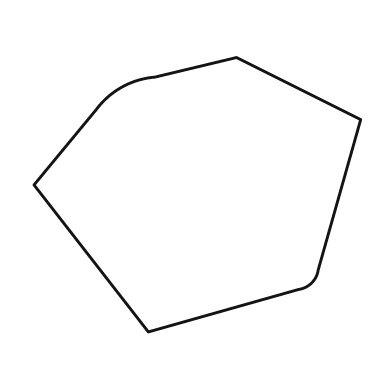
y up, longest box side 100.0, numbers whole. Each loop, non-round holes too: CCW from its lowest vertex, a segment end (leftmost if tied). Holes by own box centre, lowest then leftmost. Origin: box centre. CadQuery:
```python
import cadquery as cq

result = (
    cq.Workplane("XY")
    .moveTo(-15.0, -42.0)
    .lineTo(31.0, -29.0)
    .threePointArc((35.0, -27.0), (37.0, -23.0))
    .lineTo(50.0, 23.0)
    .lineTo(12.0, 42.0)
    .lineTo(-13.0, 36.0)
    .threePointArc((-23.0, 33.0), (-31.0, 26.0))
    .lineTo(-50.0, 3.0)
    .close()
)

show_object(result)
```